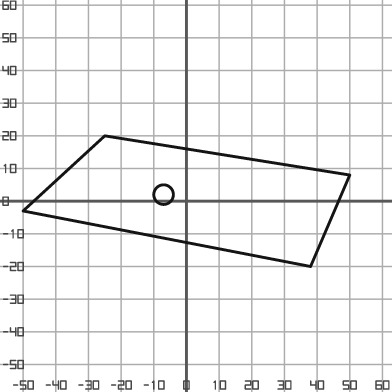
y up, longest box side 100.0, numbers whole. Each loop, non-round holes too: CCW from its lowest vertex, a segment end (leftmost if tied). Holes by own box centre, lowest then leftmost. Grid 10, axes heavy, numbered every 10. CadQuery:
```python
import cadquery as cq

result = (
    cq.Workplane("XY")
    .moveTo(38.0, -20.0)
    .lineTo(50.0, 8.0)
    .lineTo(-25.0, 20.0)
    .lineTo(-50.0, -3.0)
    .close()
    .moveTo(-7.0, 2.0)
    .circle(3.0)
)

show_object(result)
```